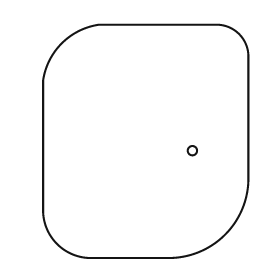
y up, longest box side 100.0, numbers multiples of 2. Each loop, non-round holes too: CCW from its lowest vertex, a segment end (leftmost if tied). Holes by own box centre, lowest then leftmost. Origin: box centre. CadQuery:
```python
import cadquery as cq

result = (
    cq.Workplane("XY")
    .moveTo(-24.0, -50.0)
    .lineTo(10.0, -50.0)
    .threePointArc((34.0, -40.0), (44.0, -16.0))
    .lineTo(44.0, 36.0)
    .threePointArc((40.0, 46.0), (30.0, 50.0))
    .lineTo(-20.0, 50.0)
    .threePointArc((-36.0, 42.0), (-44.0, 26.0))
    .lineTo(-44.0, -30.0)
    .threePointArc((-38.0, -44.0), (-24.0, -50.0))
    .close()
    .moveTo(20.0, -4.0)
    .circle(2.0)
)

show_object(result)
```